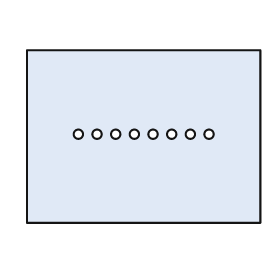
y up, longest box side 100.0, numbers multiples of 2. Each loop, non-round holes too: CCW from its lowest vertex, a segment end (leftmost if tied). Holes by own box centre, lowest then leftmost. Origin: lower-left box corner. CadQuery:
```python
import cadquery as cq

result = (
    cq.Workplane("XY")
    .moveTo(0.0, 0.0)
    .lineTo(100.0, 0.0)
    .lineTo(100.0, 74.0)
    .lineTo(0.0, 74.0)
    .close()
    .moveTo(22.0, 38.0)
    .circle(2.0)
    .moveTo(30.0, 38.0)
    .circle(2.0)
    .moveTo(38.0, 38.0)
    .circle(2.0)
    .moveTo(46.0, 38.0)
    .circle(2.0)
    .moveTo(54.0, 38.0)
    .circle(2.0)
    .moveTo(62.0, 38.0)
    .circle(2.0)
    .moveTo(70.0, 38.0)
    .circle(2.0)
    .moveTo(78.0, 38.0)
    .circle(2.0)
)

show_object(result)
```